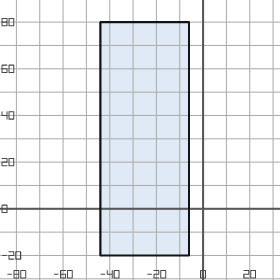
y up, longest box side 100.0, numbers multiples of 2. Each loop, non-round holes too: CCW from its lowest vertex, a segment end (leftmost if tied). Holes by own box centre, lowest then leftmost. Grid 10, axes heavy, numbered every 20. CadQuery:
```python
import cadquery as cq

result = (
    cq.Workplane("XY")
    .moveTo(-44.0, -20.0)
    .lineTo(-6.0, -20.0)
    .lineTo(-6.0, 80.0)
    .lineTo(-44.0, 80.0)
    .close()
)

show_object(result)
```